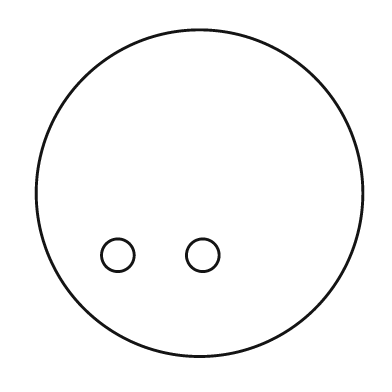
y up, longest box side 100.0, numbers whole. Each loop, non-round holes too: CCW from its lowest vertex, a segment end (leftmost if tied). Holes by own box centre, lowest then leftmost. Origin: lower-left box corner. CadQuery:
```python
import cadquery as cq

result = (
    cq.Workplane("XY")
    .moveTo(50.0, 50.0)
    .circle(50.0)
    .moveTo(25.0, 31.0)
    .circle(5.0)
    .moveTo(51.0, 31.0)
    .circle(5.0)
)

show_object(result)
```